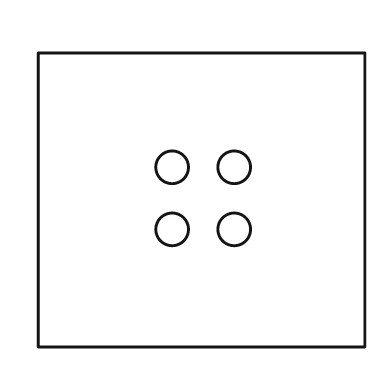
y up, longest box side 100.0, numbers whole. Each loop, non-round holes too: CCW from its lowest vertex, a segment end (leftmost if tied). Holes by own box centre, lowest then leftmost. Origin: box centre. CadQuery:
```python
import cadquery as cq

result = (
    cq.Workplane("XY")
    .moveTo(-50.0, -45.0)
    .lineTo(50.0, -45.0)
    .lineTo(50.0, 45.0)
    .lineTo(-50.0, 45.0)
    .close()
    .moveTo(-9.0, -9.0)
    .circle(5.0)
    .moveTo(10.0, -9.0)
    .circle(5.0)
    .moveTo(-9.0, 10.0)
    .circle(5.0)
    .moveTo(10.0, 10.0)
    .circle(5.0)
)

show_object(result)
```